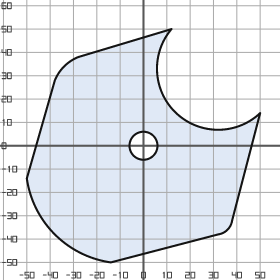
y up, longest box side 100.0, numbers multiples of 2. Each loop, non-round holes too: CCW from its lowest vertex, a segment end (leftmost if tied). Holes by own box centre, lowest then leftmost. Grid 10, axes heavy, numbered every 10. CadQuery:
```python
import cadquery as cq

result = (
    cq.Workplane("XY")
    .moveTo(-14.0, -50.0)
    .lineTo(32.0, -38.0)
    .threePointArc((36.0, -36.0), (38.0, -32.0))
    .lineTo(50.0, 14.0)
    .threePointArc((14.0, 14.0), (12.0, 50.0))
    .lineTo(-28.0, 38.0)
    .threePointArc((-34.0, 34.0), (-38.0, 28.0))
    .lineTo(-50.0, -14.0)
    .threePointArc((-38.0, -38.0), (-14.0, -50.0))
    .close()
    .moveTo(0.0, 0.0)
    .circle(6.0)
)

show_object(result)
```